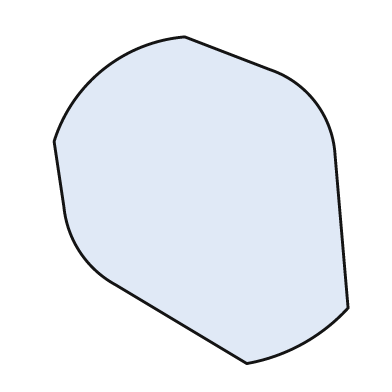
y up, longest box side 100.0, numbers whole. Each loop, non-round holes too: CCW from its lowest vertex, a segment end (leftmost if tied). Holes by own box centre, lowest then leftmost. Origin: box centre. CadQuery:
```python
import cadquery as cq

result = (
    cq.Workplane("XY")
    .moveTo(14.0, -50.0)
    .threePointArc((31.0, -44.0), (45.0, -33.0))
    .lineTo(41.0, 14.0)
    .threePointArc((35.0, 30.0), (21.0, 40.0))
    .lineTo(-5.0, 50.0)
    .threePointArc((-30.0, 40.0), (-45.0, 18.0))
    .lineTo(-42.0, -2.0)
    .threePointArc((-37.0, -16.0), (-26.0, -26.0))
    .close()
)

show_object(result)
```